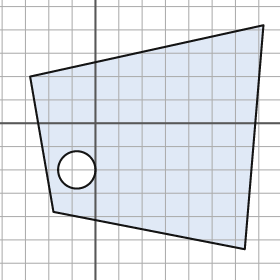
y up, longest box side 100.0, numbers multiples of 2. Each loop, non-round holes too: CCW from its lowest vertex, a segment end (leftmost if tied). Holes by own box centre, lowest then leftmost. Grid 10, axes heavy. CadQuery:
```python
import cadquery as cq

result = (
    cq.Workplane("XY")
    .moveTo(64.0, -54.0)
    .lineTo(72.0, 42.0)
    .lineTo(-28.0, 20.0)
    .lineTo(-18.0, -38.0)
    .close()
    .moveTo(-8.0, -20.0)
    .circle(8.0)
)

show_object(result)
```